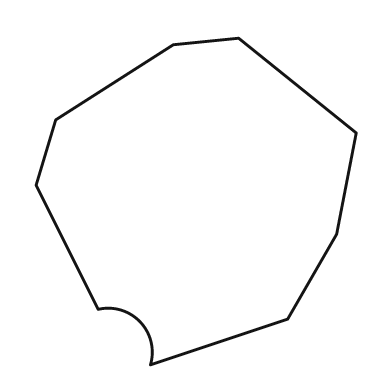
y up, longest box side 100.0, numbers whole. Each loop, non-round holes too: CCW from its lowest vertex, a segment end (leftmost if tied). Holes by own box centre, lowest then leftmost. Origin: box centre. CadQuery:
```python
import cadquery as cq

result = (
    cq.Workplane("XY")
    .moveTo(-14.0, -50.0)
    .lineTo(28.0, -36.0)
    .lineTo(43.0, -10.0)
    .lineTo(49.0, 21.0)
    .lineTo(13.0, 50.0)
    .lineTo(-7.0, 48.0)
    .lineTo(-43.0, 25.0)
    .lineTo(-49.0, 5.0)
    .lineTo(-30.0, -33.0)
    .threePointArc((-17.0, -37.0), (-14.0, -50.0))
    .close()
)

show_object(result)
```